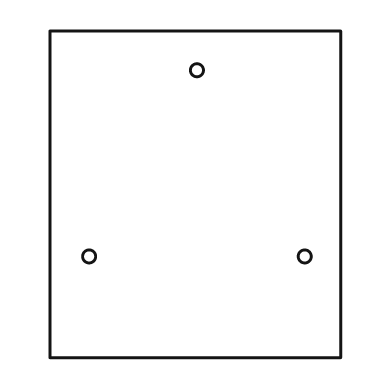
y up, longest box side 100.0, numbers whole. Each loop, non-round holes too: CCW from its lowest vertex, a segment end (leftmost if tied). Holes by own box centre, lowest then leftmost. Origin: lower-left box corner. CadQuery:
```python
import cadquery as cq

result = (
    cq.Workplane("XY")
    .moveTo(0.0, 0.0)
    .lineTo(89.0, 0.0)
    .lineTo(89.0, 100.0)
    .lineTo(0.0, 100.0)
    .close()
    .moveTo(12.0, 31.0)
    .circle(2.0)
    .moveTo(78.0, 31.0)
    .circle(2.0)
    .moveTo(45.0, 88.0)
    .circle(2.0)
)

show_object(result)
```